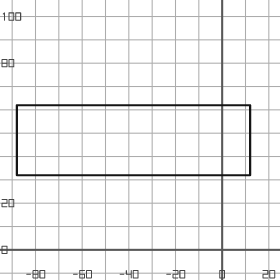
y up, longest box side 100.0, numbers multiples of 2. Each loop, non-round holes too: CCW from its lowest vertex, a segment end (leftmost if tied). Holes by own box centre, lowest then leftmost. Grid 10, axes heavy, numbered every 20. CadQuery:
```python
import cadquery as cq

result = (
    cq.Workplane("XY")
    .moveTo(-88.0, 32.0)
    .lineTo(12.0, 32.0)
    .lineTo(12.0, 62.0)
    .lineTo(-88.0, 62.0)
    .close()
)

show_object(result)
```